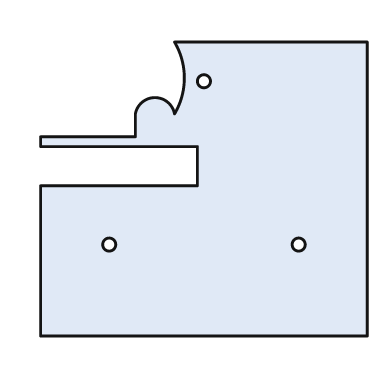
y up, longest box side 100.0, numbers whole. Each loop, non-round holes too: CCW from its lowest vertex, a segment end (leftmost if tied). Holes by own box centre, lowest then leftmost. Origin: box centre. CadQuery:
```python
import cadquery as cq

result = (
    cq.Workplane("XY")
    .moveTo(-50.0, -45.0)
    .lineTo(50.0, -45.0)
    .lineTo(50.0, 45.0)
    .lineTo(-9.0, 45.0)
    .threePointArc((-6.0, 34.0), (-9.0, 23.0))
    .threePointArc((-15.0, 28.0), (-21.0, 23.0))
    .lineTo(-21.0, 16.0)
    .lineTo(-50.0, 16.0)
    .lineTo(-50.0, 13.0)
    .lineTo(-2.0, 13.0)
    .lineTo(-2.0, 1.0)
    .lineTo(-50.0, 1.0)
    .close()
    .moveTo(-29.0, -17.0)
    .circle(2.0)
    .moveTo(29.0, -17.0)
    .circle(2.0)
    .moveTo(0.0, 33.0)
    .circle(2.0)
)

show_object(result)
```